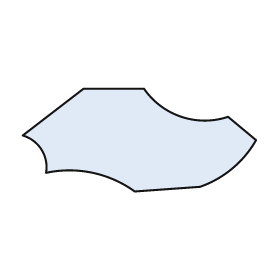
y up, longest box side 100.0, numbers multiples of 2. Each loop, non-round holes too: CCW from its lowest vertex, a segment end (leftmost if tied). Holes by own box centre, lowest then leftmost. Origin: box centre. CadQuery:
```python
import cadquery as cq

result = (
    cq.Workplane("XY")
    .moveTo(-2.0, -22.0)
    .lineTo(26.0, -20.0)
    .threePointArc((40.0, -12.0), (50.0, 0.0))
    .lineTo(38.0, 10.0)
    .threePointArc((18.0, 10.0), (2.0, 22.0))
    .lineTo(-24.0, 22.0)
    .lineTo(-50.0, 2.0)
    .threePointArc((-42.0, -4.0), (-40.0, -14.0))
    .threePointArc((-20.0, -14.0), (-2.0, -22.0))
    .close()
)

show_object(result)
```